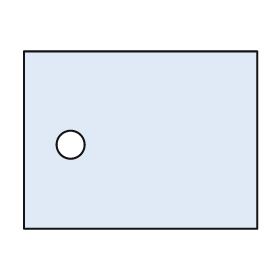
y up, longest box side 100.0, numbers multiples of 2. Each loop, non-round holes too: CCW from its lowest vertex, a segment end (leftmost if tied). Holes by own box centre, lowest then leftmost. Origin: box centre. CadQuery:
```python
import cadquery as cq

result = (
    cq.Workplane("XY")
    .moveTo(-50.0, -38.0)
    .lineTo(50.0, -38.0)
    .lineTo(50.0, 38.0)
    .lineTo(-50.0, 38.0)
    .close()
    .moveTo(-30.0, -2.0)
    .circle(6.0)
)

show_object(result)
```